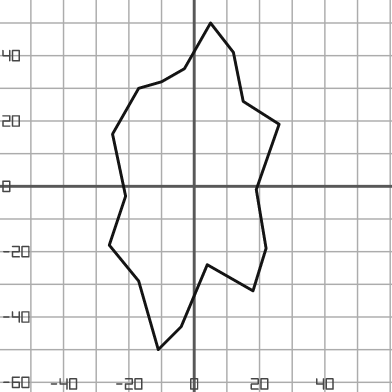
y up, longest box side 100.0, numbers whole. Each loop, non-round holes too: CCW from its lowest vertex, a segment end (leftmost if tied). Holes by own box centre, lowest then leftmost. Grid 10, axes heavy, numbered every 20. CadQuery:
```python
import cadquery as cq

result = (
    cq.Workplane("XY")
    .moveTo(-11.0, -50.0)
    .lineTo(-4.0, -43.0)
    .lineTo(4.0, -24.0)
    .lineTo(18.0, -32.0)
    .lineTo(22.0, -19.0)
    .lineTo(19.0, -1.0)
    .lineTo(26.0, 19.0)
    .lineTo(15.0, 26.0)
    .lineTo(12.0, 41.0)
    .lineTo(5.0, 50.0)
    .lineTo(-3.0, 36.0)
    .lineTo(-10.0, 32.0)
    .lineTo(-17.0, 30.0)
    .lineTo(-25.0, 16.0)
    .lineTo(-21.0, -3.0)
    .lineTo(-26.0, -18.0)
    .lineTo(-17.0, -29.0)
    .close()
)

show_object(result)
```